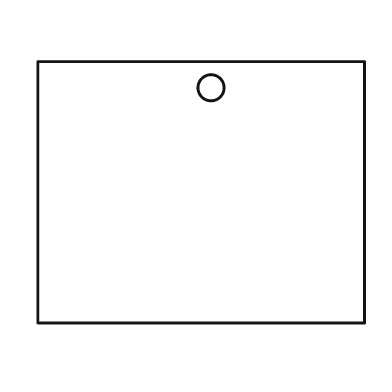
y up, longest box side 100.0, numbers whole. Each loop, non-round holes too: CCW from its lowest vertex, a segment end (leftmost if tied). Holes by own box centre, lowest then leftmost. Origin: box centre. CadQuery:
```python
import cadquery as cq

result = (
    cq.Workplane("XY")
    .moveTo(-50.0, -40.0)
    .lineTo(50.0, -40.0)
    .lineTo(50.0, 40.0)
    .lineTo(-50.0, 40.0)
    .close()
    .moveTo(3.0, 32.0)
    .circle(4.0)
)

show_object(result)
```